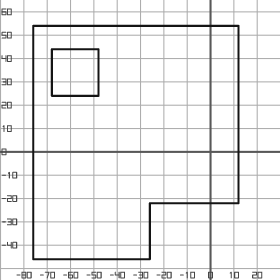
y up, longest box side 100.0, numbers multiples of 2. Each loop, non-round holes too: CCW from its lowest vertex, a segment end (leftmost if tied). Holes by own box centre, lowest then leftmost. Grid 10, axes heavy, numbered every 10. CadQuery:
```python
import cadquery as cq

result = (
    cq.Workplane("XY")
    .moveTo(-76.0, -46.0)
    .lineTo(-26.0, -46.0)
    .lineTo(-26.0, -22.0)
    .lineTo(12.0, -22.0)
    .lineTo(12.0, 54.0)
    .lineTo(-76.0, 54.0)
    .close()
    .moveTo(-68.0, 24.0)
    .lineTo(-48.0, 24.0)
    .lineTo(-48.0, 44.0)
    .lineTo(-68.0, 44.0)
    .close()
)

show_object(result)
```